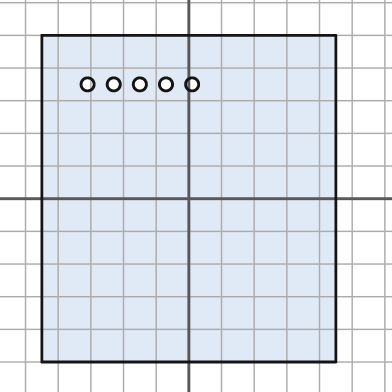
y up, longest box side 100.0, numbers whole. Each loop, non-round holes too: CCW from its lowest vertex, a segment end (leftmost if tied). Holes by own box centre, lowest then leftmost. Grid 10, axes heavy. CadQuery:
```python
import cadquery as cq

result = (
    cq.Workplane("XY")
    .moveTo(-45.0, -50.0)
    .lineTo(45.0, -50.0)
    .lineTo(45.0, 50.0)
    .lineTo(-45.0, 50.0)
    .close()
    .moveTo(-31.0, 35.0)
    .circle(2.0)
    .moveTo(-23.0, 35.0)
    .circle(2.0)
    .moveTo(-15.0, 35.0)
    .circle(2.0)
    .moveTo(-7.0, 35.0)
    .circle(2.0)
    .moveTo(1.0, 35.0)
    .circle(2.0)
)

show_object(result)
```